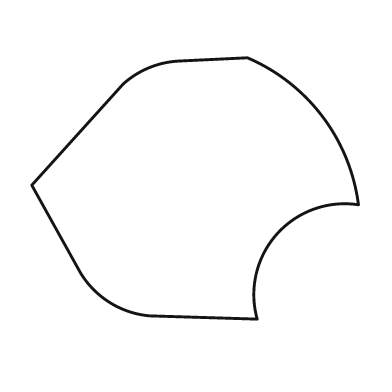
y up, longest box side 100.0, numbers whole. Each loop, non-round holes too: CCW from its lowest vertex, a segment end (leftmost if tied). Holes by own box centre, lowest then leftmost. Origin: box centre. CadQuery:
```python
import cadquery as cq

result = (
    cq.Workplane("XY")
    .moveTo(19.0, -40.0)
    .threePointArc((25.0, -14.0), (50.0, -5.0))
    .threePointArc((39.0, 22.0), (16.0, 40.0))
    .lineTo(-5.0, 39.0)
    .threePointArc((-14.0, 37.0), (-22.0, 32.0))
    .lineTo(-50.0, 1.0)
    .lineTo(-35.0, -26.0)
    .threePointArc((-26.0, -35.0), (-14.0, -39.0))
    .close()
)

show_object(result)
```